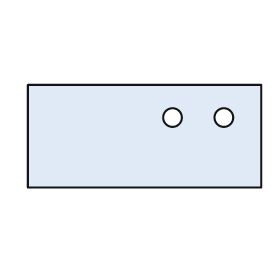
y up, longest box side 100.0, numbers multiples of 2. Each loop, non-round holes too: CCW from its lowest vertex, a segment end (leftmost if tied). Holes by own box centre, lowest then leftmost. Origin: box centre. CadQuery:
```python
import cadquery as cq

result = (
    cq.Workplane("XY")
    .moveTo(-50.0, -22.0)
    .lineTo(50.0, -22.0)
    .lineTo(50.0, 22.0)
    .lineTo(-50.0, 22.0)
    .close()
    .moveTo(12.0, 8.0)
    .circle(4.0)
    .moveTo(34.0, 8.0)
    .circle(4.0)
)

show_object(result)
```